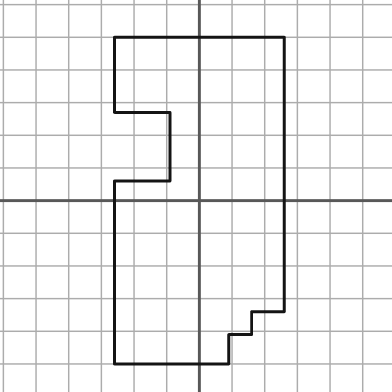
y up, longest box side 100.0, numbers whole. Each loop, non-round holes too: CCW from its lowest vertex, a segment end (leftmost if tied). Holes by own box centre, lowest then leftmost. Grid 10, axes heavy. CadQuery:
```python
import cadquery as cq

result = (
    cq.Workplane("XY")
    .moveTo(-26.0, -50.0)
    .lineTo(9.0, -50.0)
    .lineTo(9.0, -41.0)
    .lineTo(16.0, -41.0)
    .lineTo(16.0, -34.0)
    .lineTo(26.0, -34.0)
    .lineTo(26.0, 50.0)
    .lineTo(-26.0, 50.0)
    .lineTo(-26.0, 27.0)
    .lineTo(-9.0, 27.0)
    .lineTo(-9.0, 6.0)
    .lineTo(-26.0, 6.0)
    .close()
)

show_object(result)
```